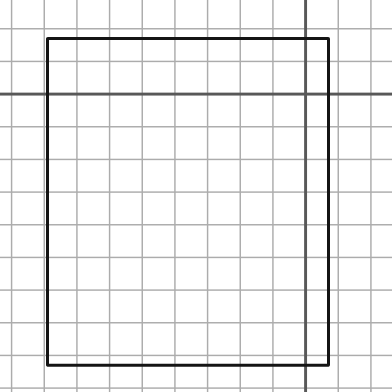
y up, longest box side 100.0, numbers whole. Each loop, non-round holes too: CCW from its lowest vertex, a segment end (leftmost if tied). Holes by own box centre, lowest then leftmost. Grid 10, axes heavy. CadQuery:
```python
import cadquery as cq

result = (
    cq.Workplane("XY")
    .moveTo(-79.0, -83.0)
    .lineTo(7.0, -83.0)
    .lineTo(7.0, 17.0)
    .lineTo(-79.0, 17.0)
    .close()
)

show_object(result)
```